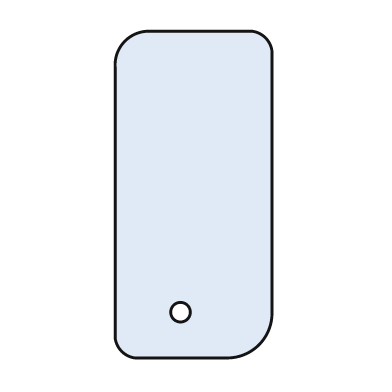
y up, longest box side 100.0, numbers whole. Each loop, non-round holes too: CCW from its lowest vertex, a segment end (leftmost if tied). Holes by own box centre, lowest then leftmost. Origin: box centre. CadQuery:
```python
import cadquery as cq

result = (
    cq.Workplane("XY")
    .moveTo(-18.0, -50.0)
    .lineTo(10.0, -50.0)
    .threePointArc((20.0, -46.0), (24.0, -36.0))
    .lineTo(24.0, 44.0)
    .threePointArc((22.0, 48.0), (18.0, 50.0))
    .lineTo(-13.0, 50.0)
    .threePointArc((-21.0, 47.0), (-24.0, 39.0))
    .lineTo(-24.0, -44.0)
    .threePointArc((-22.0, -48.0), (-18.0, -50.0))
    .close()
    .moveTo(-4.0, -36.0)
    .circle(3.0)
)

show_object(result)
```